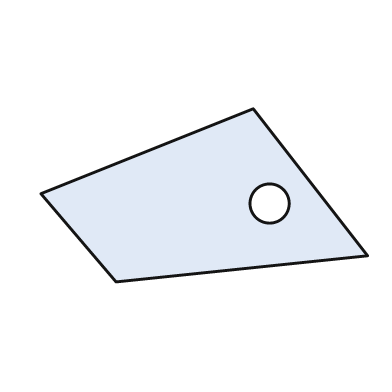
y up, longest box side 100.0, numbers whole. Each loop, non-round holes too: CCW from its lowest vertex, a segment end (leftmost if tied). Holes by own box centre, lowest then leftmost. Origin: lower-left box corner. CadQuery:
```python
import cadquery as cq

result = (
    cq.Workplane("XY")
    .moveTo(23.0, 0.0)
    .lineTo(100.0, 8.0)
    .lineTo(65.0, 53.0)
    .lineTo(0.0, 27.0)
    .close()
    .moveTo(70.0, 24.0)
    .circle(6.0)
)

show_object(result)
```